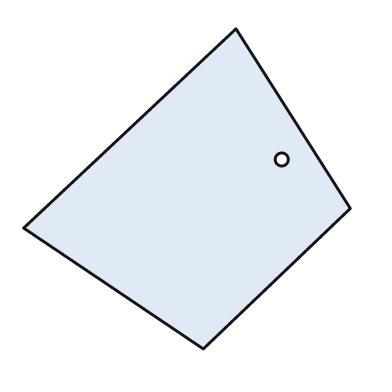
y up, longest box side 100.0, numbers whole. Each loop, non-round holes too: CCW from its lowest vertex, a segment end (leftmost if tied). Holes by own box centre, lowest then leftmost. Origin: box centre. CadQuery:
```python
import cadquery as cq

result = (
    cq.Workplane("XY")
    .moveTo(5.0, -49.0)
    .lineTo(50.0, -6.0)
    .lineTo(15.0, 49.0)
    .lineTo(-50.0, -12.0)
    .close()
    .moveTo(29.0, 9.0)
    .circle(2.0)
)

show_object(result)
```